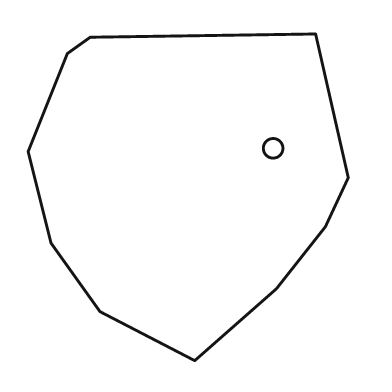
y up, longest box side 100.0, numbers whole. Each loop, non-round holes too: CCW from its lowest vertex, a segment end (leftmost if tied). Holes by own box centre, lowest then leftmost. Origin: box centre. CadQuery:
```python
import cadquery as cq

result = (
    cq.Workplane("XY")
    .moveTo(2.0, -50.0)
    .lineTo(27.0, -28.0)
    .lineTo(42.0, -9.0)
    .lineTo(49.0, 6.0)
    .lineTo(39.0, 50.0)
    .lineTo(-30.0, 49.0)
    .lineTo(-37.0, 44.0)
    .lineTo(-49.0, 14.0)
    .lineTo(-42.0, -14.0)
    .lineTo(-27.0, -35.0)
    .close()
    .moveTo(26.0, 15.0)
    .circle(3.0)
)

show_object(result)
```